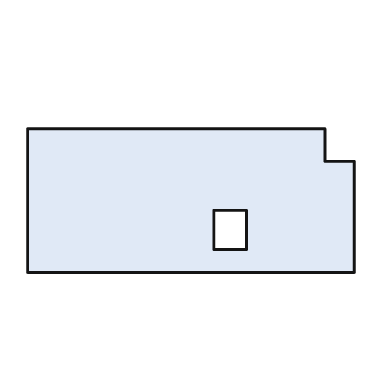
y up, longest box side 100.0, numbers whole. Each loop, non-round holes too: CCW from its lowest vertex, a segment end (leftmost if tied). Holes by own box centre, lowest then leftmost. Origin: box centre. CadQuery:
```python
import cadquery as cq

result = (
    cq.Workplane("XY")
    .moveTo(-50.0, -22.0)
    .lineTo(50.0, -22.0)
    .lineTo(50.0, 12.0)
    .lineTo(41.0, 12.0)
    .lineTo(41.0, 22.0)
    .lineTo(-50.0, 22.0)
    .close()
    .moveTo(7.0, -15.0)
    .lineTo(17.0, -15.0)
    .lineTo(17.0, -3.0)
    .lineTo(7.0, -3.0)
    .close()
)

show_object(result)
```